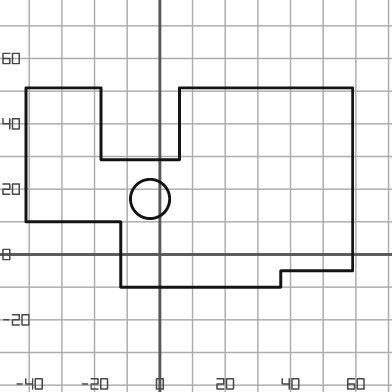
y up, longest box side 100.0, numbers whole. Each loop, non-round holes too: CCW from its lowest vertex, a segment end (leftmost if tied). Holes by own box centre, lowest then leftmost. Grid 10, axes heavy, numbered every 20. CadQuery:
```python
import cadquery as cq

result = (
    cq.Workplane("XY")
    .moveTo(-12.0, -10.0)
    .lineTo(37.0, -10.0)
    .lineTo(37.0, -5.0)
    .lineTo(59.0, -5.0)
    .lineTo(59.0, 51.0)
    .lineTo(6.0, 51.0)
    .lineTo(6.0, 29.0)
    .lineTo(-18.0, 29.0)
    .lineTo(-18.0, 51.0)
    .lineTo(-41.0, 51.0)
    .lineTo(-41.0, 10.0)
    .lineTo(-12.0, 10.0)
    .close()
    .moveTo(-3.0, 17.0)
    .circle(6.0)
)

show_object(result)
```